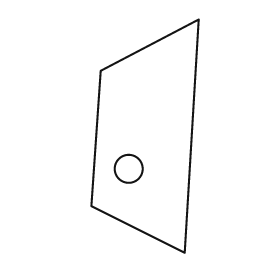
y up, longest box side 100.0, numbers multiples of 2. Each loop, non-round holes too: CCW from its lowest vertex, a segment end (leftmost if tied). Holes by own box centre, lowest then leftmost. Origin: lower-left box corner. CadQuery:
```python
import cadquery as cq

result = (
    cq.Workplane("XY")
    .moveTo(40.0, 0.0)
    .lineTo(46.0, 100.0)
    .lineTo(4.0, 78.0)
    .lineTo(0.0, 20.0)
    .close()
    .moveTo(16.0, 36.0)
    .circle(6.0)
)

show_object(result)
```